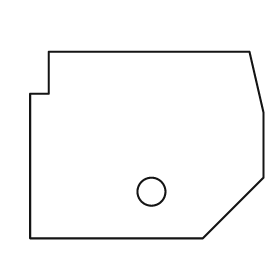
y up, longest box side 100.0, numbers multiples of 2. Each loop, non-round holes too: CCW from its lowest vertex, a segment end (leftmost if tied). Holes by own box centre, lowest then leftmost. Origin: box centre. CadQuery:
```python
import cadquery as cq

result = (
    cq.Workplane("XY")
    .moveTo(-50.0, -40.0)
    .lineTo(24.0, -40.0)
    .lineTo(50.0, -14.0)
    .lineTo(50.0, 14.0)
    .lineTo(44.0, 40.0)
    .lineTo(-42.0, 40.0)
    .lineTo(-42.0, 22.0)
    .lineTo(-50.0, 22.0)
    .close()
    .moveTo(2.0, -20.0)
    .circle(6.0)
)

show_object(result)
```